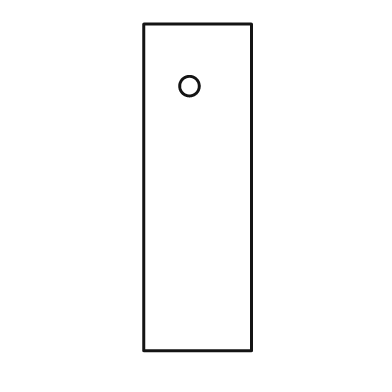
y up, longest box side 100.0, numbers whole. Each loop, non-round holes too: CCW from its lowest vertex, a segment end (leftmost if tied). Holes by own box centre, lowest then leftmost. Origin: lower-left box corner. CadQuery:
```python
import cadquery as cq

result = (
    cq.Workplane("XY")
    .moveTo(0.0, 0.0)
    .lineTo(33.0, 0.0)
    .lineTo(33.0, 100.0)
    .lineTo(0.0, 100.0)
    .close()
    .moveTo(14.0, 81.0)
    .circle(3.0)
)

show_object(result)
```